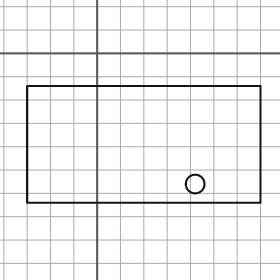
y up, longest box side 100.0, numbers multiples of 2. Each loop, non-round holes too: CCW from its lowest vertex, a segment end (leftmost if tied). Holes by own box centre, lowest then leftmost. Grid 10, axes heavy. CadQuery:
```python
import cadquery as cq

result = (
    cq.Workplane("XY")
    .moveTo(-30.0, -64.0)
    .lineTo(70.0, -64.0)
    .lineTo(70.0, -14.0)
    .lineTo(-30.0, -14.0)
    .close()
    .moveTo(42.0, -56.0)
    .circle(4.0)
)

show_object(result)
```